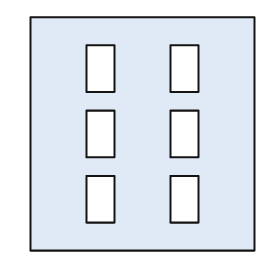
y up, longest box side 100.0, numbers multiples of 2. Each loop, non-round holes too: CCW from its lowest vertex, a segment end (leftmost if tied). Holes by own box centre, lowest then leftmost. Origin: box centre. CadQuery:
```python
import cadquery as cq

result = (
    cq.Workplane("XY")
    .moveTo(-48.0, -50.0)
    .lineTo(48.0, -50.0)
    .lineTo(48.0, 50.0)
    .lineTo(-48.0, 50.0)
    .close()
    .moveTo(-24.0, -38.0)
    .lineTo(-12.0, -38.0)
    .lineTo(-12.0, -18.0)
    .lineTo(-24.0, -18.0)
    .close()
    .moveTo(12.0, -38.0)
    .lineTo(24.0, -38.0)
    .lineTo(24.0, -18.0)
    .lineTo(12.0, -18.0)
    .close()
    .moveTo(-24.0, -10.0)
    .lineTo(-12.0, -10.0)
    .lineTo(-12.0, 10.0)
    .lineTo(-24.0, 10.0)
    .close()
    .moveTo(12.0, -10.0)
    .lineTo(24.0, -10.0)
    .lineTo(24.0, 10.0)
    .lineTo(12.0, 10.0)
    .close()
    .moveTo(-24.0, 18.0)
    .lineTo(-12.0, 18.0)
    .lineTo(-12.0, 38.0)
    .lineTo(-24.0, 38.0)
    .close()
    .moveTo(12.0, 18.0)
    .lineTo(24.0, 18.0)
    .lineTo(24.0, 38.0)
    .lineTo(12.0, 38.0)
    .close()
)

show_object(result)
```